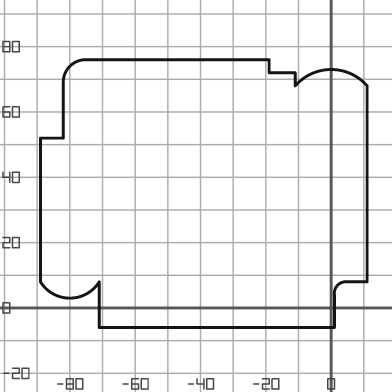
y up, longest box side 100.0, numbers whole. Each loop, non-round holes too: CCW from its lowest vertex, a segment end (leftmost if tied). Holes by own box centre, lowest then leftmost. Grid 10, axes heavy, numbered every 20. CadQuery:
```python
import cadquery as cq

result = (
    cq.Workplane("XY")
    .moveTo(-71.0, -6.0)
    .lineTo(1.0, -6.0)
    .lineTo(1.0, 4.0)
    .threePointArc((2.0, 7.0), (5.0, 8.0))
    .lineTo(11.0, 8.0)
    .lineTo(11.0, 68.0)
    .threePointArc((0.0, 73.0), (-11.0, 68.0))
    .lineTo(-11.0, 72.0)
    .lineTo(-19.0, 72.0)
    .lineTo(-19.0, 76.0)
    .lineTo(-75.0, 76.0)
    .threePointArc((-80.0, 74.0), (-82.0, 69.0))
    .lineTo(-82.0, 52.0)
    .lineTo(-89.0, 52.0)
    .lineTo(-89.0, 8.0)
    .threePointArc((-80.0, 3.0), (-71.0, 8.0))
    .close()
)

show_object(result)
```